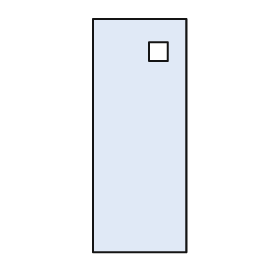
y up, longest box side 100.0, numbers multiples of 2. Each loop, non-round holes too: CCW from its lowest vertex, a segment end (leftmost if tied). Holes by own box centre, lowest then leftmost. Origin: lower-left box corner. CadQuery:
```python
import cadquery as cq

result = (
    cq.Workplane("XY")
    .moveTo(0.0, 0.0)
    .lineTo(40.0, 0.0)
    .lineTo(40.0, 100.0)
    .lineTo(0.0, 100.0)
    .close()
    .moveTo(24.0, 82.0)
    .lineTo(32.0, 82.0)
    .lineTo(32.0, 90.0)
    .lineTo(24.0, 90.0)
    .close()
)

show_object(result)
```